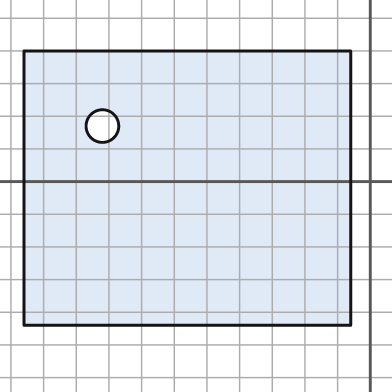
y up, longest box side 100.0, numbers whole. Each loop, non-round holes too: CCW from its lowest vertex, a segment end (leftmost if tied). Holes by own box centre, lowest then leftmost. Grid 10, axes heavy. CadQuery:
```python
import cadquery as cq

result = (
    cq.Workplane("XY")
    .moveTo(-106.0, -44.0)
    .lineTo(-6.0, -44.0)
    .lineTo(-6.0, 40.0)
    .lineTo(-106.0, 40.0)
    .close()
    .moveTo(-82.0, 17.0)
    .circle(5.0)
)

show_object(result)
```